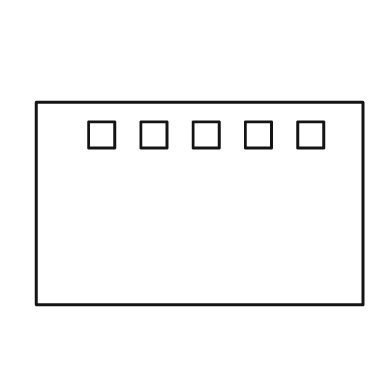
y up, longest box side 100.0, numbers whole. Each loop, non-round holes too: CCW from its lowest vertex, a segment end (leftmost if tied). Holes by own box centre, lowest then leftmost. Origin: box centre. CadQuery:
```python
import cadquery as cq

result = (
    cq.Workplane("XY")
    .moveTo(-50.0, -31.0)
    .lineTo(50.0, -31.0)
    .lineTo(50.0, 31.0)
    .lineTo(-50.0, 31.0)
    .close()
    .moveTo(-34.0, 17.0)
    .lineTo(-26.0, 17.0)
    .lineTo(-26.0, 25.0)
    .lineTo(-34.0, 25.0)
    .close()
    .moveTo(-18.0, 17.0)
    .lineTo(-10.0, 17.0)
    .lineTo(-10.0, 25.0)
    .lineTo(-18.0, 25.0)
    .close()
    .moveTo(-2.0, 17.0)
    .lineTo(6.0, 17.0)
    .lineTo(6.0, 25.0)
    .lineTo(-2.0, 25.0)
    .close()
    .moveTo(14.0, 17.0)
    .lineTo(22.0, 17.0)
    .lineTo(22.0, 25.0)
    .lineTo(14.0, 25.0)
    .close()
    .moveTo(30.0, 17.0)
    .lineTo(38.0, 17.0)
    .lineTo(38.0, 25.0)
    .lineTo(30.0, 25.0)
    .close()
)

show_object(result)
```